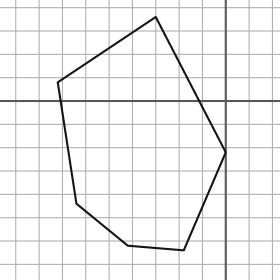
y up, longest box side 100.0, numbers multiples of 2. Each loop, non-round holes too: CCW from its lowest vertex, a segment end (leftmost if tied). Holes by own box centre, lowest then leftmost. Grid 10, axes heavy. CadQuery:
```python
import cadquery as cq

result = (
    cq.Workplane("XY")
    .moveTo(-18.0, -64.0)
    .lineTo(0.0, -22.0)
    .lineTo(-30.0, 36.0)
    .lineTo(-72.0, 8.0)
    .lineTo(-64.0, -44.0)
    .lineTo(-42.0, -62.0)
    .close()
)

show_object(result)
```